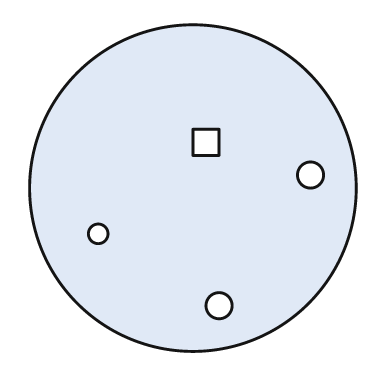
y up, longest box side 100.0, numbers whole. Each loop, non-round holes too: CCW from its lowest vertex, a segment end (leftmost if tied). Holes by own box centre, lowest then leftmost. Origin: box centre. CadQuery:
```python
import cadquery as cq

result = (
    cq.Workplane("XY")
    .moveTo(0.0, 0.0)
    .circle(50.0)
    .moveTo(8.0, -36.0)
    .circle(4.0)
    .moveTo(-29.0, -14.0)
    .circle(3.0)
    .moveTo(36.0, 4.0)
    .circle(4.0)
    .moveTo(0.0, 10.0)
    .lineTo(8.0, 10.0)
    .lineTo(8.0, 18.0)
    .lineTo(0.0, 18.0)
    .close()
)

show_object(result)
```